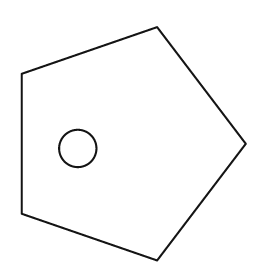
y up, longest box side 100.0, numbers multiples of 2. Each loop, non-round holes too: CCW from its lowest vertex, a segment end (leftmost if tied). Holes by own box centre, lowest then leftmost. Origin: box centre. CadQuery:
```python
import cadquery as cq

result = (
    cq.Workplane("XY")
    .moveTo(10.0, -50.0)
    .lineTo(48.0, 0.0)
    .lineTo(10.0, 50.0)
    .lineTo(-48.0, 30.0)
    .lineTo(-48.0, -30.0)
    .close()
    .moveTo(-24.0, -2.0)
    .circle(8.0)
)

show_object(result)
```